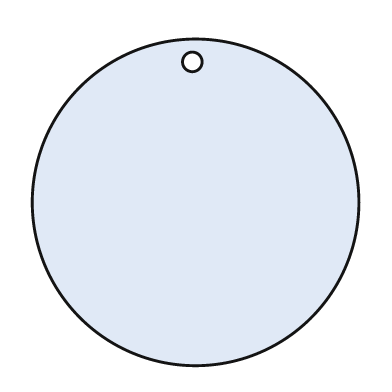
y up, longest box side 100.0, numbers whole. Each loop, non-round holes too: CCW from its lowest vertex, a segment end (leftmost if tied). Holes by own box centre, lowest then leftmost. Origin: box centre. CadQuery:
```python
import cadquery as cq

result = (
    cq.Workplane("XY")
    .moveTo(0.0, 0.0)
    .circle(50.0)
    .moveTo(-1.0, 43.0)
    .circle(3.0)
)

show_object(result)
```